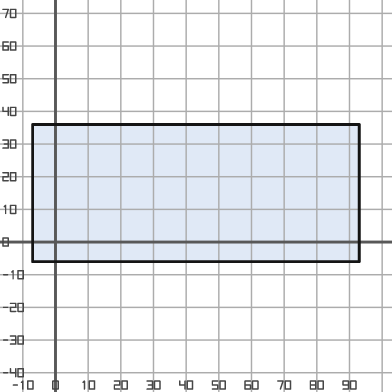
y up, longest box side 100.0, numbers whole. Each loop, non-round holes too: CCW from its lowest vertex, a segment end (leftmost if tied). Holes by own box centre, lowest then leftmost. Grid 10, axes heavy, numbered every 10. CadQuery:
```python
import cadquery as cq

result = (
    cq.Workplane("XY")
    .moveTo(-7.0, -6.0)
    .lineTo(93.0, -6.0)
    .lineTo(93.0, 36.0)
    .lineTo(-7.0, 36.0)
    .close()
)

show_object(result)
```